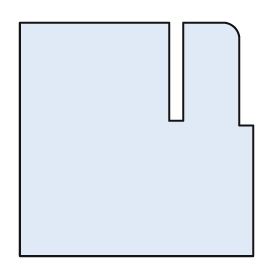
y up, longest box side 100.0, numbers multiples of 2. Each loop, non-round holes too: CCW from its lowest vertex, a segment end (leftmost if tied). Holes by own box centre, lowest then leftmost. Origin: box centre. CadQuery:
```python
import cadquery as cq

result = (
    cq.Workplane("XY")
    .moveTo(-50.0, -50.0)
    .lineTo(50.0, -50.0)
    .lineTo(50.0, 6.0)
    .lineTo(44.0, 6.0)
    .lineTo(44.0, 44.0)
    .threePointArc((42.0, 48.0), (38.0, 50.0))
    .lineTo(20.0, 50.0)
    .lineTo(20.0, 8.0)
    .lineTo(14.0, 8.0)
    .lineTo(14.0, 50.0)
    .lineTo(-50.0, 50.0)
    .close()
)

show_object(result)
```